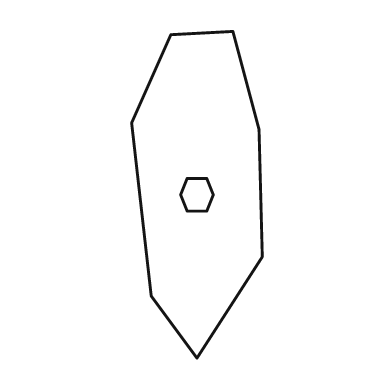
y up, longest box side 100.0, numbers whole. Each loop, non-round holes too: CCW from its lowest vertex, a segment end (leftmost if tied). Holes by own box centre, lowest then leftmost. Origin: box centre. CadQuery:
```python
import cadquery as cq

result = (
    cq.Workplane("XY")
    .moveTo(0.0, -50.0)
    .lineTo(20.0, -19.0)
    .lineTo(19.0, 20.0)
    .lineTo(11.0, 50.0)
    .lineTo(-8.0, 49.0)
    .lineTo(-20.0, 22.0)
    .lineTo(-14.0, -31.0)
    .close()
    .moveTo(-3.0, -5.0)
    .lineTo(3.0, -5.0)
    .lineTo(5.0, 0.0)
    .lineTo(3.0, 5.0)
    .lineTo(-3.0, 5.0)
    .lineTo(-5.0, 0.0)
    .close()
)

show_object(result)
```